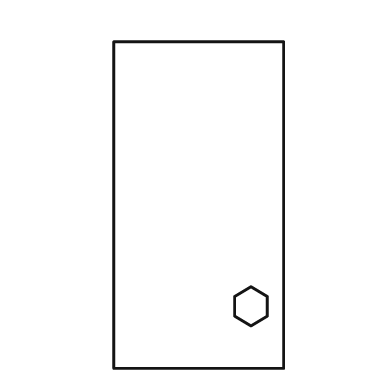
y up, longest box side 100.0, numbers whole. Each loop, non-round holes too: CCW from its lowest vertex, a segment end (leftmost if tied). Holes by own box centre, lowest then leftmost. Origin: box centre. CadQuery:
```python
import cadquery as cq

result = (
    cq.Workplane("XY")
    .moveTo(-26.0, -50.0)
    .lineTo(26.0, -50.0)
    .lineTo(26.0, 50.0)
    .lineTo(-26.0, 50.0)
    .close()
    .moveTo(16.0, -37.0)
    .lineTo(21.0, -34.0)
    .lineTo(21.0, -28.0)
    .lineTo(16.0, -25.0)
    .lineTo(11.0, -28.0)
    .lineTo(11.0, -34.0)
    .close()
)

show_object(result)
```